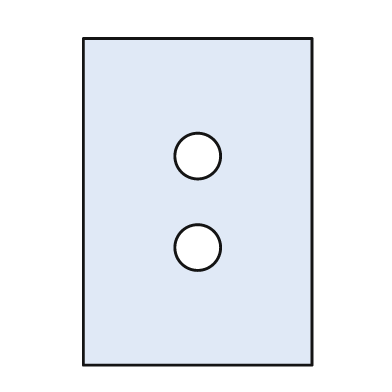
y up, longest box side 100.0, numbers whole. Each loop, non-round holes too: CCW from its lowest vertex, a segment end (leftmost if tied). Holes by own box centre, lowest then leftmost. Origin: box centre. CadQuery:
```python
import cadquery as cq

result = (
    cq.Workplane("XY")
    .moveTo(-35.0, -50.0)
    .lineTo(35.0, -50.0)
    .lineTo(35.0, 50.0)
    .lineTo(-35.0, 50.0)
    .close()
    .moveTo(0.0, -14.0)
    .circle(7.0)
    .moveTo(0.0, 14.0)
    .circle(7.0)
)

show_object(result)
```